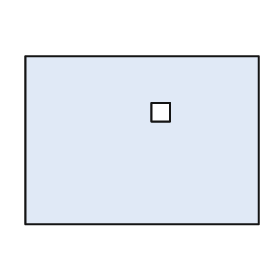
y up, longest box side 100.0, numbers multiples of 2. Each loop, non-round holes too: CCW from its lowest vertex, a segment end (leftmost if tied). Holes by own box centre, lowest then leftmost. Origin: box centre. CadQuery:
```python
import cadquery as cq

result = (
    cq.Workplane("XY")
    .moveTo(-50.0, -36.0)
    .lineTo(50.0, -36.0)
    .lineTo(50.0, 36.0)
    .lineTo(-50.0, 36.0)
    .close()
    .moveTo(4.0, 8.0)
    .lineTo(12.0, 8.0)
    .lineTo(12.0, 16.0)
    .lineTo(4.0, 16.0)
    .close()
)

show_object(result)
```